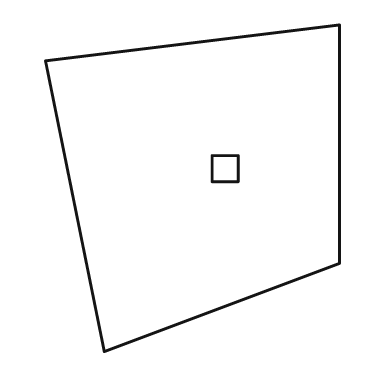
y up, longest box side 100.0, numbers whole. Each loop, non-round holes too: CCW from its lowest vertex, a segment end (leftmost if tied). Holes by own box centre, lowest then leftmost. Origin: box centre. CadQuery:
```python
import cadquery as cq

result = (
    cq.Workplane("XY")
    .moveTo(-27.0, -50.0)
    .lineTo(45.0, -23.0)
    .lineTo(45.0, 50.0)
    .lineTo(-45.0, 39.0)
    .close()
    .moveTo(6.0, 2.0)
    .lineTo(14.0, 2.0)
    .lineTo(14.0, 10.0)
    .lineTo(6.0, 10.0)
    .close()
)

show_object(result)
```